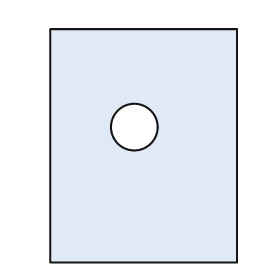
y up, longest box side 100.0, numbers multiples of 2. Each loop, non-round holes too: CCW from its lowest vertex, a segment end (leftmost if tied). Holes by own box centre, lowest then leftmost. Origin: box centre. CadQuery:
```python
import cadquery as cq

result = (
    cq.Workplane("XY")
    .moveTo(-40.0, -50.0)
    .lineTo(40.0, -50.0)
    .lineTo(40.0, 50.0)
    .lineTo(-40.0, 50.0)
    .close()
    .moveTo(-4.0, 8.0)
    .circle(10.0)
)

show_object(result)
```